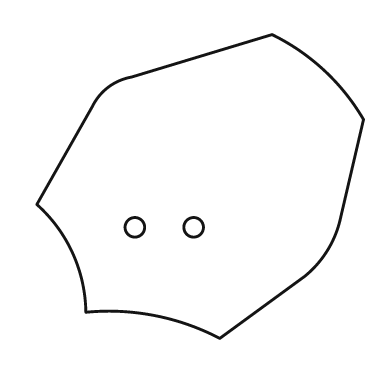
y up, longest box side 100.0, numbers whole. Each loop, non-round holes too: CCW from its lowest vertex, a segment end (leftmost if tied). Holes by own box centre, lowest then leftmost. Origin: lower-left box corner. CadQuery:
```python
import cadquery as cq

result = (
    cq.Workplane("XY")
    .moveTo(56.0, 0.0)
    .lineTo(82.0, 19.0)
    .threePointArc((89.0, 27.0), (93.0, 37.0))
    .lineTo(100.0, 67.0)
    .threePointArc((88.0, 82.0), (72.0, 93.0))
    .lineTo(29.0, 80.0)
    .threePointArc((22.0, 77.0), (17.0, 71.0))
    .lineTo(0.0, 41.0)
    .threePointArc((11.0, 26.0), (15.0, 8.0))
    .threePointArc((36.0, 7.0), (56.0, 0.0))
    .close()
    .moveTo(30.0, 34.0)
    .circle(3.0)
    .moveTo(48.0, 34.0)
    .circle(3.0)
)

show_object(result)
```